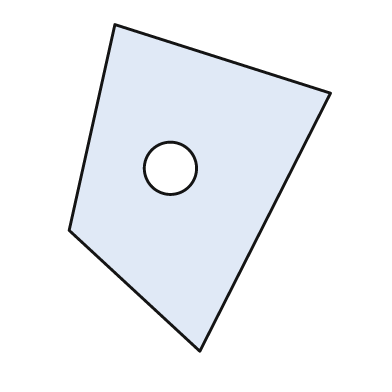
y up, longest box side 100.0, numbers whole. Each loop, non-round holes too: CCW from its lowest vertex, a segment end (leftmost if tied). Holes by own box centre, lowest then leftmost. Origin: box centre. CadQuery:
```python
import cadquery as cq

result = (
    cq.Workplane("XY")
    .moveTo(0.0, -50.0)
    .lineTo(40.0, 29.0)
    .lineTo(-26.0, 50.0)
    .lineTo(-40.0, -13.0)
    .close()
    .moveTo(-9.0, 6.0)
    .circle(8.0)
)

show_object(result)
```